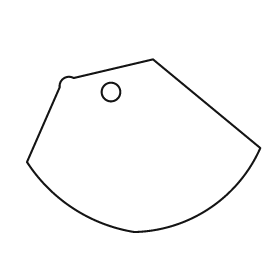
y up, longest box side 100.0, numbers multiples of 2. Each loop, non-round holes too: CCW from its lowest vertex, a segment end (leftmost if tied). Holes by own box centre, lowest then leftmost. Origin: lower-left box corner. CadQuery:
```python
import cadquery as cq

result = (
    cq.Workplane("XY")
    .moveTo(46.0, 0.0)
    .threePointArc((78.0, 10.0), (100.0, 36.0))
    .lineTo(54.0, 74.0)
    .lineTo(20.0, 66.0)
    .threePointArc((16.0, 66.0), (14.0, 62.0))
    .lineTo(0.0, 30.0)
    .threePointArc((20.0, 10.0), (46.0, 0.0))
    .close()
    .moveTo(36.0, 60.0)
    .circle(4.0)
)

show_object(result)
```